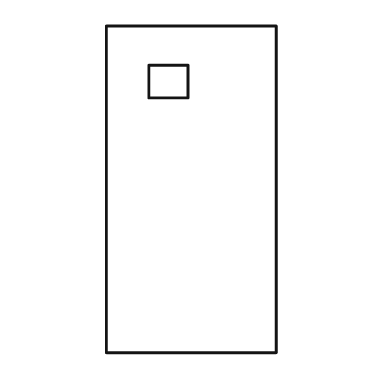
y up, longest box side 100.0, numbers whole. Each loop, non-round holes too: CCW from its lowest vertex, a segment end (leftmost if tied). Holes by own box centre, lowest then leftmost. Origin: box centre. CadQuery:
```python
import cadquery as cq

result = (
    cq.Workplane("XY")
    .moveTo(-26.0, -50.0)
    .lineTo(26.0, -50.0)
    .lineTo(26.0, 50.0)
    .lineTo(-26.0, 50.0)
    .close()
    .moveTo(-13.0, 28.0)
    .lineTo(-1.0, 28.0)
    .lineTo(-1.0, 38.0)
    .lineTo(-13.0, 38.0)
    .close()
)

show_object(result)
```